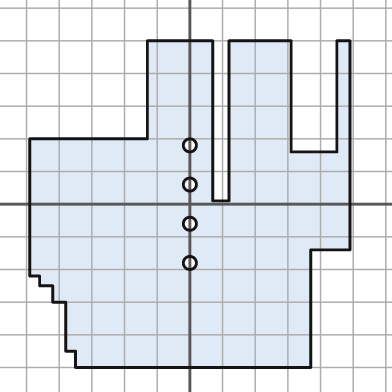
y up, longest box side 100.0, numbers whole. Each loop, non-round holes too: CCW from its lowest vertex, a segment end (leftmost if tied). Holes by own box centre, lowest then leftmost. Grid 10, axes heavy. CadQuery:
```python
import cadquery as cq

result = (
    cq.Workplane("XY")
    .moveTo(-35.0, -50.0)
    .lineTo(37.0, -50.0)
    .lineTo(37.0, -14.0)
    .lineTo(49.0, -14.0)
    .lineTo(49.0, 50.0)
    .lineTo(45.0, 50.0)
    .lineTo(45.0, 16.0)
    .lineTo(31.0, 16.0)
    .lineTo(31.0, 50.0)
    .lineTo(12.0, 50.0)
    .lineTo(12.0, 1.0)
    .lineTo(7.0, 1.0)
    .lineTo(7.0, 50.0)
    .lineTo(-13.0, 50.0)
    .lineTo(-13.0, 20.0)
    .lineTo(-49.0, 20.0)
    .lineTo(-49.0, -22.0)
    .lineTo(-46.0, -22.0)
    .lineTo(-46.0, -25.0)
    .lineTo(-42.0, -25.0)
    .lineTo(-42.0, -30.0)
    .lineTo(-38.0, -30.0)
    .lineTo(-38.0, -45.0)
    .lineTo(-35.0, -45.0)
    .close()
    .moveTo(0.0, -18.0)
    .circle(2.0)
    .moveTo(0.0, -6.0)
    .circle(2.0)
    .moveTo(0.0, 6.0)
    .circle(2.0)
    .moveTo(0.0, 18.0)
    .circle(2.0)
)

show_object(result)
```